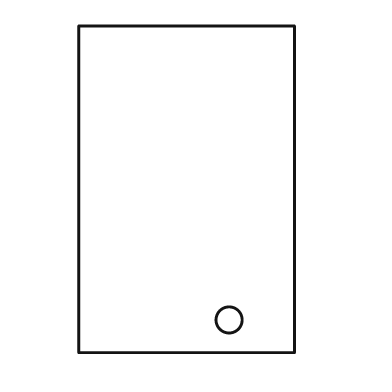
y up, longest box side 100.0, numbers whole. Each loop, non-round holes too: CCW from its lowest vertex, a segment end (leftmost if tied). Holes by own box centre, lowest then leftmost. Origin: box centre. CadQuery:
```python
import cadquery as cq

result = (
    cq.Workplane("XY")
    .moveTo(-33.0, -50.0)
    .lineTo(33.0, -50.0)
    .lineTo(33.0, 50.0)
    .lineTo(-33.0, 50.0)
    .close()
    .moveTo(13.0, -40.0)
    .circle(4.0)
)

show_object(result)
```